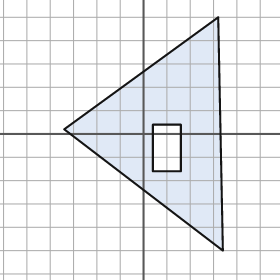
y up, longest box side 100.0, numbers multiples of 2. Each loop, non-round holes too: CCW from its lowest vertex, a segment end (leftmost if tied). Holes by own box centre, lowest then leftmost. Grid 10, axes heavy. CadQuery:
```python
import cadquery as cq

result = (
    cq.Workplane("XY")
    .moveTo(34.0, -50.0)
    .lineTo(32.0, 50.0)
    .lineTo(-34.0, 2.0)
    .close()
    .moveTo(4.0, -16.0)
    .lineTo(16.0, -16.0)
    .lineTo(16.0, 4.0)
    .lineTo(4.0, 4.0)
    .close()
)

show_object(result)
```